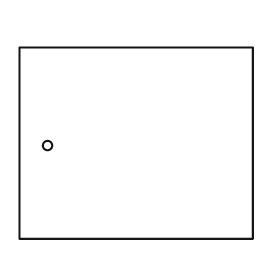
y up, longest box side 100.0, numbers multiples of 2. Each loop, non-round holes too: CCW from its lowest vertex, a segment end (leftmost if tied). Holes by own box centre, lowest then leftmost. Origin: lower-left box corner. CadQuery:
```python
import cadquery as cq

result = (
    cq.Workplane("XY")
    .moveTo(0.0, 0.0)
    .lineTo(100.0, 0.0)
    .lineTo(100.0, 82.0)
    .lineTo(0.0, 82.0)
    .close()
    .moveTo(12.0, 40.0)
    .circle(2.0)
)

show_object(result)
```